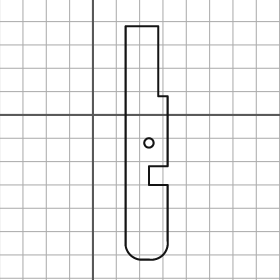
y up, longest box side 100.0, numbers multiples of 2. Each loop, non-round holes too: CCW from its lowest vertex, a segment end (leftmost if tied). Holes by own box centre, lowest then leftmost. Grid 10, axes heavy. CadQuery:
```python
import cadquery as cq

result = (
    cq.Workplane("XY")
    .moveTo(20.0, -62.0)
    .lineTo(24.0, -62.0)
    .threePointArc((30.0, -60.0), (32.0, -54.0))
    .lineTo(32.0, -30.0)
    .lineTo(24.0, -30.0)
    .lineTo(24.0, -22.0)
    .lineTo(32.0, -22.0)
    .lineTo(32.0, 8.0)
    .lineTo(28.0, 8.0)
    .lineTo(28.0, 38.0)
    .lineTo(14.0, 38.0)
    .lineTo(14.0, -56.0)
    .threePointArc((16.0, -60.0), (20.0, -62.0))
    .close()
    .moveTo(24.0, -12.0)
    .circle(2.0)
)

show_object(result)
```